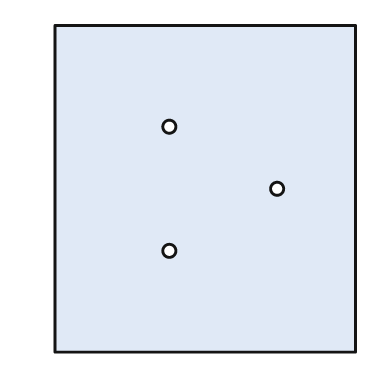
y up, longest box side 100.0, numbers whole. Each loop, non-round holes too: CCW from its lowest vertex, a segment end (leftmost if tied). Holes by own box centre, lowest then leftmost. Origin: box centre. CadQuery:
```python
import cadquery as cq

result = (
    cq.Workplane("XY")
    .moveTo(-46.0, -50.0)
    .lineTo(46.0, -50.0)
    .lineTo(46.0, 50.0)
    .lineTo(-46.0, 50.0)
    .close()
    .moveTo(-11.0, -19.0)
    .circle(2.0)
    .moveTo(22.0, 0.0)
    .circle(2.0)
    .moveTo(-11.0, 19.0)
    .circle(2.0)
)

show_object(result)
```